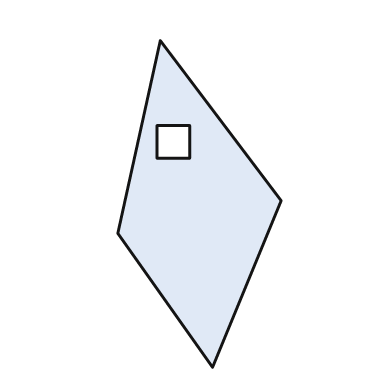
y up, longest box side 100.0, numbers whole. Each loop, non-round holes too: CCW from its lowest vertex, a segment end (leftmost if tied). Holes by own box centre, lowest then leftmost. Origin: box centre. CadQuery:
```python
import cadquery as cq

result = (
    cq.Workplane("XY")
    .moveTo(4.0, -50.0)
    .lineTo(25.0, 1.0)
    .lineTo(-12.0, 50.0)
    .lineTo(-25.0, -9.0)
    .close()
    .moveTo(-13.0, 14.0)
    .lineTo(-3.0, 14.0)
    .lineTo(-3.0, 24.0)
    .lineTo(-13.0, 24.0)
    .close()
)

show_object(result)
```